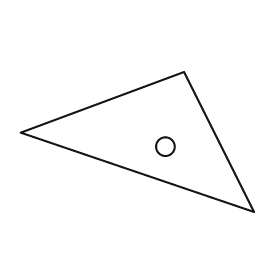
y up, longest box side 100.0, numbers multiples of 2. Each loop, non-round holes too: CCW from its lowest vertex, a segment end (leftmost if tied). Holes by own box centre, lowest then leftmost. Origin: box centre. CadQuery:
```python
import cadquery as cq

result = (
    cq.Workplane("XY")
    .moveTo(50.0, -30.0)
    .lineTo(20.0, 30.0)
    .lineTo(-50.0, 4.0)
    .close()
    .moveTo(12.0, -2.0)
    .circle(4.0)
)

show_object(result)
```